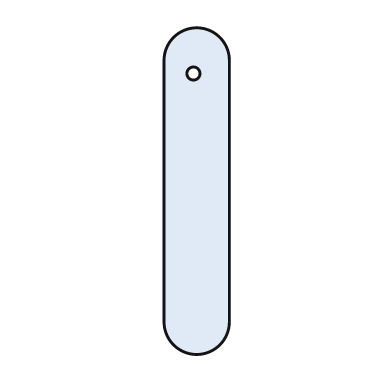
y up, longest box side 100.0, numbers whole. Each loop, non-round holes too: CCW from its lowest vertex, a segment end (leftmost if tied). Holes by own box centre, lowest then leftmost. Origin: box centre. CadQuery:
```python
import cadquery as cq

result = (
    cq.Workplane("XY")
    .moveTo(-10.0, -40.0)
    .threePointArc((0.0, -50.0), (10.0, -40.0))
    .lineTo(10.0, 40.0)
    .threePointArc((0.0, 50.0), (-10.0, 40.0))
    .close()
    .moveTo(-1.0, 36.0)
    .circle(2.0)
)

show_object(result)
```